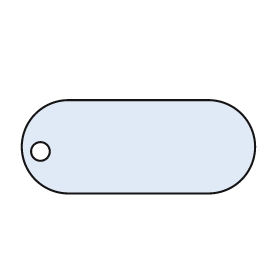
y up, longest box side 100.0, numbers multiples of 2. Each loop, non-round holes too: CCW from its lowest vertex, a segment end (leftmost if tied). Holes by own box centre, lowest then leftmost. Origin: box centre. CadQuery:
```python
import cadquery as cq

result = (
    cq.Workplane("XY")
    .moveTo(-30.0, -20.0)
    .lineTo(30.0, -20.0)
    .threePointArc((50.0, 0.0), (30.0, 20.0))
    .lineTo(-30.0, 20.0)
    .threePointArc((-50.0, 0.0), (-30.0, -20.0))
    .close()
    .moveTo(-42.0, -2.0)
    .circle(4.0)
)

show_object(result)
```